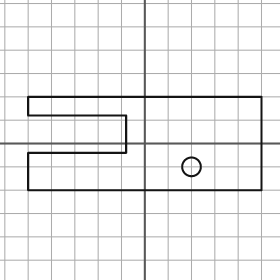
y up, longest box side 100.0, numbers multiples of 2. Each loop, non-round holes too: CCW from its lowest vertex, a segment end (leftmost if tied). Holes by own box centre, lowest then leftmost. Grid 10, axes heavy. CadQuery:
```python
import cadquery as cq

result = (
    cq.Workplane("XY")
    .moveTo(-50.0, -20.0)
    .lineTo(50.0, -20.0)
    .lineTo(50.0, 20.0)
    .lineTo(-50.0, 20.0)
    .lineTo(-50.0, 12.0)
    .lineTo(-8.0, 12.0)
    .lineTo(-8.0, -4.0)
    .lineTo(-50.0, -4.0)
    .close()
    .moveTo(20.0, -10.0)
    .circle(4.0)
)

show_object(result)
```